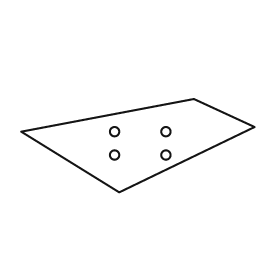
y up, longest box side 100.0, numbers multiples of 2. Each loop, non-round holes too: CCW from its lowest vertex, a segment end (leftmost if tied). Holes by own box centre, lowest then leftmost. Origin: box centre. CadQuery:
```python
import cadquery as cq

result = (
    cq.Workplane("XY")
    .moveTo(-8.0, -20.0)
    .lineTo(50.0, 8.0)
    .lineTo(24.0, 20.0)
    .lineTo(-50.0, 6.0)
    .close()
    .moveTo(-10.0, -4.0)
    .circle(2.0)
    .moveTo(12.0, -4.0)
    .circle(2.0)
    .moveTo(-10.0, 6.0)
    .circle(2.0)
    .moveTo(12.0, 6.0)
    .circle(2.0)
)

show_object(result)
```